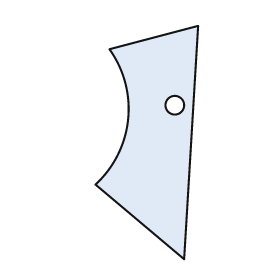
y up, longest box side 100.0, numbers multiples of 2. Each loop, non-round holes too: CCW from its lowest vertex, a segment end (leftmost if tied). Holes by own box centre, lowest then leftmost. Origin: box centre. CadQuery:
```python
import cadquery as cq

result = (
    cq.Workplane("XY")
    .moveTo(16.0, -50.0)
    .lineTo(22.0, 50.0)
    .lineTo(-16.0, 40.0)
    .threePointArc((-8.0, 10.0), (-22.0, -18.0))
    .close()
    .moveTo(12.0, 16.0)
    .circle(4.0)
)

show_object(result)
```